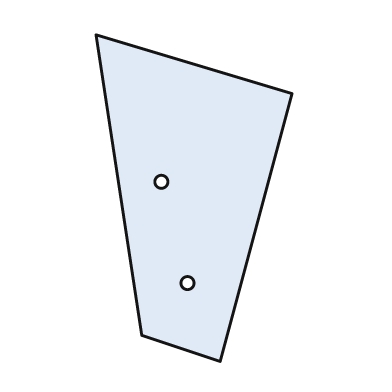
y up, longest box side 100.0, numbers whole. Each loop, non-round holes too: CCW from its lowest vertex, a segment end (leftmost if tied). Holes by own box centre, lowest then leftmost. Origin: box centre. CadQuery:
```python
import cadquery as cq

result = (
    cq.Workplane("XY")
    .moveTo(8.0, -50.0)
    .lineTo(30.0, 32.0)
    .lineTo(-30.0, 50.0)
    .lineTo(-16.0, -42.0)
    .close()
    .moveTo(-2.0, -26.0)
    .circle(2.0)
    .moveTo(-10.0, 5.0)
    .circle(2.0)
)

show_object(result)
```